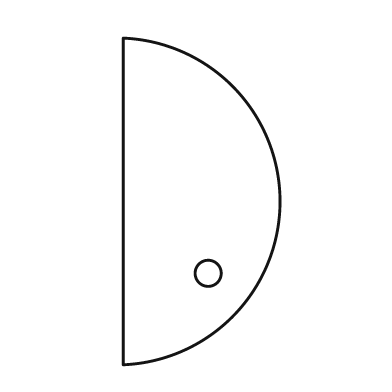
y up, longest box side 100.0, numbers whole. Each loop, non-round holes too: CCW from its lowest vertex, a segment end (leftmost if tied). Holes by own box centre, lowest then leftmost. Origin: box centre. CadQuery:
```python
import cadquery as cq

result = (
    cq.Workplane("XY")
    .moveTo(-24.0, -50.0)
    .threePointArc((24.0, 0.0), (-24.0, 50.0))
    .close()
    .moveTo(2.0, -22.0)
    .circle(4.0)
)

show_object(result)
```